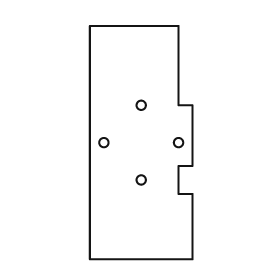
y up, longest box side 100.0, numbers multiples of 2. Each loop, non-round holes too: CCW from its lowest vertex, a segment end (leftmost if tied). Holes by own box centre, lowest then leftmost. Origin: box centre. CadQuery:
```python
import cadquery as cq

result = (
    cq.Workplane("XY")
    .moveTo(-22.0, -50.0)
    .lineTo(22.0, -50.0)
    .lineTo(22.0, -22.0)
    .lineTo(16.0, -22.0)
    .lineTo(16.0, -10.0)
    .lineTo(22.0, -10.0)
    .lineTo(22.0, 16.0)
    .lineTo(16.0, 16.0)
    .lineTo(16.0, 50.0)
    .lineTo(-22.0, 50.0)
    .close()
    .moveTo(0.0, -16.0)
    .circle(2.0)
    .moveTo(-16.0, 0.0)
    .circle(2.0)
    .moveTo(16.0, 0.0)
    .circle(2.0)
    .moveTo(0.0, 16.0)
    .circle(2.0)
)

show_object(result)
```